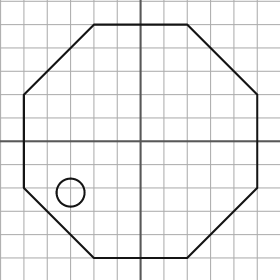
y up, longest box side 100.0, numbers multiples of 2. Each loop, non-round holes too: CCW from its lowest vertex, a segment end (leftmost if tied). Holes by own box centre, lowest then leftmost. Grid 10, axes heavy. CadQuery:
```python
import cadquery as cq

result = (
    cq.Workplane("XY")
    .moveTo(-20.0, -50.0)
    .lineTo(20.0, -50.0)
    .lineTo(50.0, -20.0)
    .lineTo(50.0, 20.0)
    .lineTo(20.0, 50.0)
    .lineTo(-20.0, 50.0)
    .lineTo(-50.0, 20.0)
    .lineTo(-50.0, -20.0)
    .close()
    .moveTo(-30.0, -22.0)
    .circle(6.0)
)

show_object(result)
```